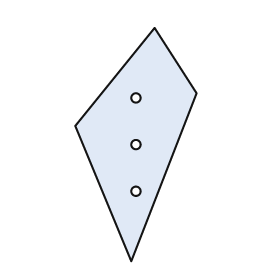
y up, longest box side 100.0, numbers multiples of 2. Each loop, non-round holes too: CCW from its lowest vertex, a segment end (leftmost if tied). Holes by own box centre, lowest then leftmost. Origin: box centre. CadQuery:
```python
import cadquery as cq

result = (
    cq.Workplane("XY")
    .moveTo(-2.0, -50.0)
    .lineTo(26.0, 22.0)
    .lineTo(8.0, 50.0)
    .lineTo(-26.0, 8.0)
    .close()
    .moveTo(0.0, -20.0)
    .circle(2.0)
    .moveTo(0.0, 0.0)
    .circle(2.0)
    .moveTo(0.0, 20.0)
    .circle(2.0)
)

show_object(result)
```